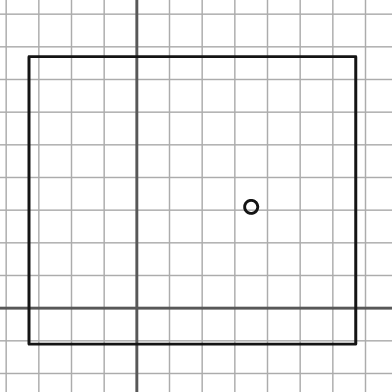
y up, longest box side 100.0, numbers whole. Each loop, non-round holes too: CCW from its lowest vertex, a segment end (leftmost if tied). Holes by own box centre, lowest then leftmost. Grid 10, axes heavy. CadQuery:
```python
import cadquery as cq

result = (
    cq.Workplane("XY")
    .moveTo(-33.0, -11.0)
    .lineTo(67.0, -11.0)
    .lineTo(67.0, 77.0)
    .lineTo(-33.0, 77.0)
    .close()
    .moveTo(35.0, 31.0)
    .circle(2.0)
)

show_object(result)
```